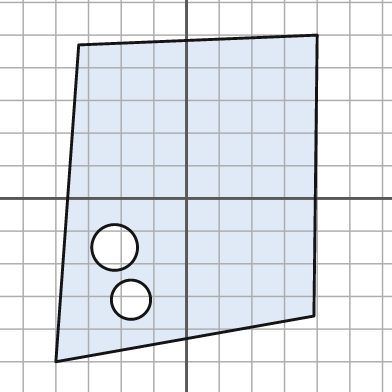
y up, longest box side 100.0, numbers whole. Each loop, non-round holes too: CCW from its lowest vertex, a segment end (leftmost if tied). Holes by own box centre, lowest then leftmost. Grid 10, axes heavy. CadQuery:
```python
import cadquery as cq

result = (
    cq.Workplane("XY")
    .moveTo(-40.0, -50.0)
    .lineTo(39.0, -36.0)
    .lineTo(40.0, 50.0)
    .lineTo(-33.0, 47.0)
    .close()
    .moveTo(-17.0, -31.0)
    .circle(6.0)
    .moveTo(-22.0, -15.0)
    .circle(7.0)
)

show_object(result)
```